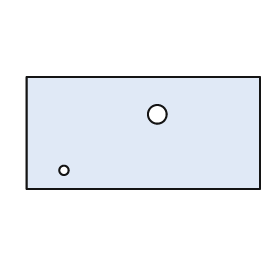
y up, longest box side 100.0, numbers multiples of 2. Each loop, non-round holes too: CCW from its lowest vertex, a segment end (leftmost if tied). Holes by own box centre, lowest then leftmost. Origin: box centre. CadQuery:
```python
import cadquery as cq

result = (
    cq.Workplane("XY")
    .moveTo(-50.0, -24.0)
    .lineTo(50.0, -24.0)
    .lineTo(50.0, 24.0)
    .lineTo(-50.0, 24.0)
    .close()
    .moveTo(-34.0, -16.0)
    .circle(2.0)
    .moveTo(6.0, 8.0)
    .circle(4.0)
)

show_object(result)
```